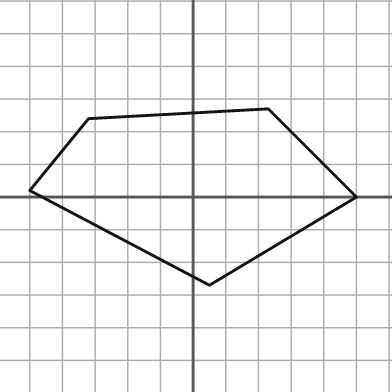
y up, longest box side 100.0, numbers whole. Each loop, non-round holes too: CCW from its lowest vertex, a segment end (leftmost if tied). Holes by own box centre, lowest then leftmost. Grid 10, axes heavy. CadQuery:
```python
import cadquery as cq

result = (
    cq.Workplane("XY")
    .moveTo(5.0, -27.0)
    .lineTo(50.0, 0.0)
    .lineTo(23.0, 27.0)
    .lineTo(-32.0, 24.0)
    .lineTo(-50.0, 2.0)
    .close()
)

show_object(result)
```